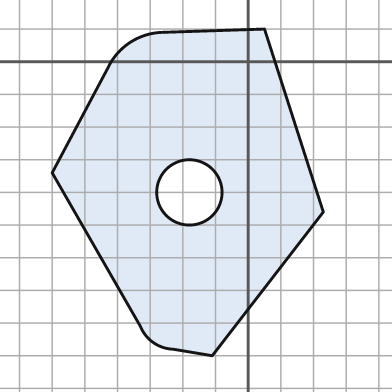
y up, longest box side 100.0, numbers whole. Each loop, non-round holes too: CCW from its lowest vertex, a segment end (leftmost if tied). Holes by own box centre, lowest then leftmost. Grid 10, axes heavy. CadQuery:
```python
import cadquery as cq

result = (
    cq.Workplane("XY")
    .moveTo(-11.0, -90.0)
    .lineTo(23.0, -46.0)
    .lineTo(5.0, 10.0)
    .lineTo(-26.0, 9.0)
    .threePointArc((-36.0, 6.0), (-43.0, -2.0))
    .lineTo(-60.0, -34.0)
    .lineTo(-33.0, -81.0)
    .threePointArc((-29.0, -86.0), (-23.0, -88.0))
    .close()
    .moveTo(-18.0, -40.0)
    .circle(10.0)
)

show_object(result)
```